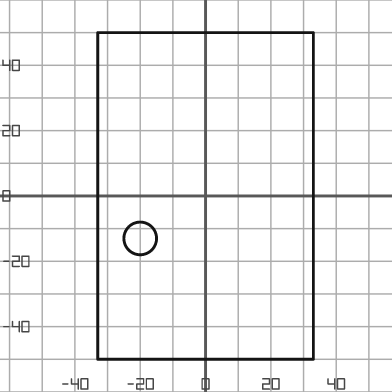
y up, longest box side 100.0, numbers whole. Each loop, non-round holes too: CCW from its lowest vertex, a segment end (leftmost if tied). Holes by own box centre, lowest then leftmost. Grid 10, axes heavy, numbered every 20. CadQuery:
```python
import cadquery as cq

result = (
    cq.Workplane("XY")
    .moveTo(-33.0, -50.0)
    .lineTo(33.0, -50.0)
    .lineTo(33.0, 50.0)
    .lineTo(-33.0, 50.0)
    .close()
    .moveTo(-20.0, -13.0)
    .circle(5.0)
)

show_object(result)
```